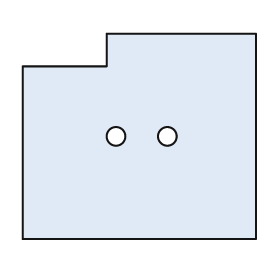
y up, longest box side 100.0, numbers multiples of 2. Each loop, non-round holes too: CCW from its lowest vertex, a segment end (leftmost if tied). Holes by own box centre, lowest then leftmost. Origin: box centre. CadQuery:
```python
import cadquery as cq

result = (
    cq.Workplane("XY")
    .moveTo(-50.0, -44.0)
    .lineTo(50.0, -44.0)
    .lineTo(50.0, 44.0)
    .lineTo(-14.0, 44.0)
    .lineTo(-14.0, 30.0)
    .lineTo(-50.0, 30.0)
    .close()
    .moveTo(-10.0, 0.0)
    .circle(4.0)
    .moveTo(12.0, 0.0)
    .circle(4.0)
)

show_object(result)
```